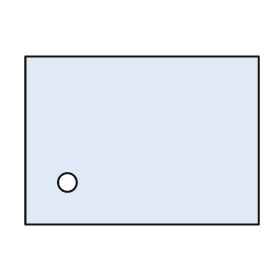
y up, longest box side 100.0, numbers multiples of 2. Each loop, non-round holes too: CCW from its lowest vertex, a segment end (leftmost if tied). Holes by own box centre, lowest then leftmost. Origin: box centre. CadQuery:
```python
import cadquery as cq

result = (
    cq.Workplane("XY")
    .moveTo(-50.0, -36.0)
    .lineTo(50.0, -36.0)
    .lineTo(50.0, 36.0)
    .lineTo(-50.0, 36.0)
    .close()
    .moveTo(-32.0, -18.0)
    .circle(4.0)
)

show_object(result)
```